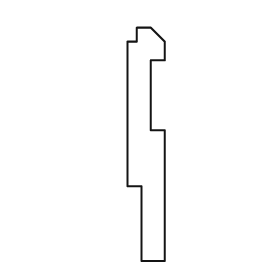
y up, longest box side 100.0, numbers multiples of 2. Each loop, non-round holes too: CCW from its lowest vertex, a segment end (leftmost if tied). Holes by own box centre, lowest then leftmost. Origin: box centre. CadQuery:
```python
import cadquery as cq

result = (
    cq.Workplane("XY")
    .moveTo(-2.0, -50.0)
    .lineTo(8.0, -50.0)
    .lineTo(8.0, 6.0)
    .lineTo(2.0, 6.0)
    .lineTo(2.0, 36.0)
    .lineTo(8.0, 36.0)
    .lineTo(8.0, 44.0)
    .lineTo(2.0, 50.0)
    .lineTo(-4.0, 50.0)
    .lineTo(-4.0, 44.0)
    .lineTo(-8.0, 44.0)
    .lineTo(-8.0, -18.0)
    .lineTo(-2.0, -18.0)
    .close()
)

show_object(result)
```